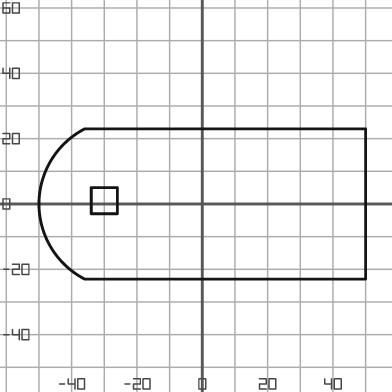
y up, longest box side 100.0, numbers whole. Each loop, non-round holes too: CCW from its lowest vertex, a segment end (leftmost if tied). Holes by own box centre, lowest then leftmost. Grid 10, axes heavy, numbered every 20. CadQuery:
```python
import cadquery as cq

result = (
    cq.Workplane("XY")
    .moveTo(-36.0, -23.0)
    .lineTo(50.0, -23.0)
    .lineTo(50.0, 23.0)
    .lineTo(-36.0, 23.0)
    .threePointArc((-50.0, 0.0), (-36.0, -23.0))
    .close()
    .moveTo(-34.0, -3.0)
    .lineTo(-26.0, -3.0)
    .lineTo(-26.0, 5.0)
    .lineTo(-34.0, 5.0)
    .close()
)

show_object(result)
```